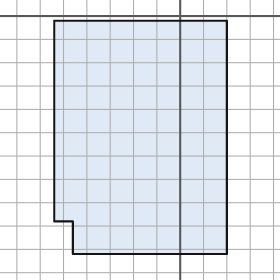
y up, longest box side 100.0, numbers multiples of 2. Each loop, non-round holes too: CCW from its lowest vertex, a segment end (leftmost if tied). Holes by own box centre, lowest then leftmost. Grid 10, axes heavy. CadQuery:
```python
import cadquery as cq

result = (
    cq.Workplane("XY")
    .moveTo(-46.0, -102.0)
    .lineTo(20.0, -102.0)
    .lineTo(20.0, -2.0)
    .lineTo(-54.0, -2.0)
    .lineTo(-54.0, -88.0)
    .lineTo(-46.0, -88.0)
    .close()
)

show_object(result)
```